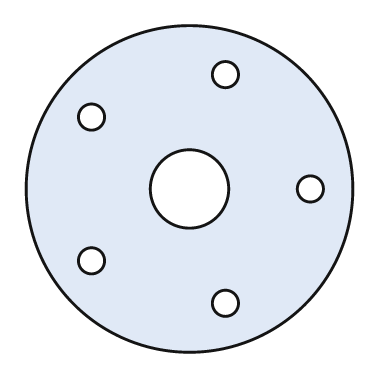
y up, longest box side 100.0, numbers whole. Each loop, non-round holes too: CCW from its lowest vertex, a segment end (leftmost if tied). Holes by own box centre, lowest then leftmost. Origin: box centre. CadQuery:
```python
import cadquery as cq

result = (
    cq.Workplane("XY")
    .moveTo(0.0, 0.0)
    .circle(50.0)
    .moveTo(11.0, -35.0)
    .circle(4.0)
    .moveTo(-30.0, -22.0)
    .circle(4.0)
    .moveTo(0.0, 0.0)
    .circle(12.0)
    .moveTo(37.0, 0.0)
    .circle(4.0)
    .moveTo(-30.0, 22.0)
    .circle(4.0)
    .moveTo(11.0, 35.0)
    .circle(4.0)
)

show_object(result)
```